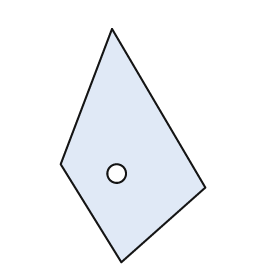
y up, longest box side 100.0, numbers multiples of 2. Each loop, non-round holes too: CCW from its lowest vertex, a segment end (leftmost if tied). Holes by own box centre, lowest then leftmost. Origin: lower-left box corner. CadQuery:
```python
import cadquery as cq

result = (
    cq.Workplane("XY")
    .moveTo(26.0, 0.0)
    .lineTo(62.0, 32.0)
    .lineTo(22.0, 100.0)
    .lineTo(0.0, 42.0)
    .close()
    .moveTo(24.0, 38.0)
    .circle(4.0)
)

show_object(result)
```